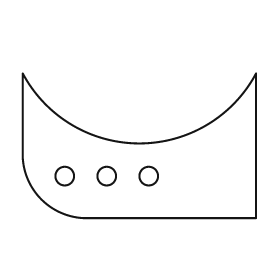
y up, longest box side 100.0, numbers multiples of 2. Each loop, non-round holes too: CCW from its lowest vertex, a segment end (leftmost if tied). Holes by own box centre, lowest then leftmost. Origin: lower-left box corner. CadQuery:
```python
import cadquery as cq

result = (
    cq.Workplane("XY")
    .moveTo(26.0, 0.0)
    .lineTo(100.0, 0.0)
    .lineTo(100.0, 62.0)
    .threePointArc((50.0, 32.0), (0.0, 62.0))
    .lineTo(0.0, 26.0)
    .threePointArc((8.0, 8.0), (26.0, 0.0))
    .close()
    .moveTo(18.0, 18.0)
    .circle(4.0)
    .moveTo(36.0, 18.0)
    .circle(4.0)
    .moveTo(54.0, 18.0)
    .circle(4.0)
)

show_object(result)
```